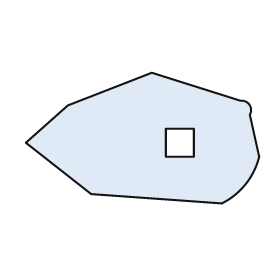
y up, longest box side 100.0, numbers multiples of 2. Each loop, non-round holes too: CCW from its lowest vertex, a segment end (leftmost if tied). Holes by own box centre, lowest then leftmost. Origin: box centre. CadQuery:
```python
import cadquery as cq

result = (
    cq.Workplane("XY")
    .moveTo(34.0, -28.0)
    .threePointArc((44.0, -20.0), (50.0, -8.0))
    .lineTo(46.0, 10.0)
    .threePointArc((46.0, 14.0), (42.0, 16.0))
    .lineTo(4.0, 28.0)
    .lineTo(-32.0, 14.0)
    .lineTo(-50.0, -2.0)
    .lineTo(-22.0, -24.0)
    .close()
    .moveTo(10.0, -8.0)
    .lineTo(22.0, -8.0)
    .lineTo(22.0, 4.0)
    .lineTo(10.0, 4.0)
    .close()
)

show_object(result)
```